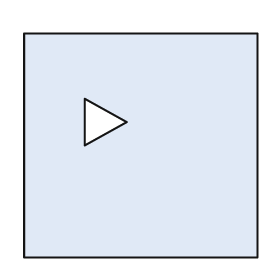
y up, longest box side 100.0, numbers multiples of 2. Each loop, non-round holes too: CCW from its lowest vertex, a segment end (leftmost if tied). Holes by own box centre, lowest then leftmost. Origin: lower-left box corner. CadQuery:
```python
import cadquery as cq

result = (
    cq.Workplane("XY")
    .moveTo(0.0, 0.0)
    .lineTo(100.0, 0.0)
    .lineTo(100.0, 96.0)
    .lineTo(0.0, 96.0)
    .close()
    .moveTo(26.0, 48.0)
    .lineTo(44.0, 58.0)
    .lineTo(26.0, 68.0)
    .close()
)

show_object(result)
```